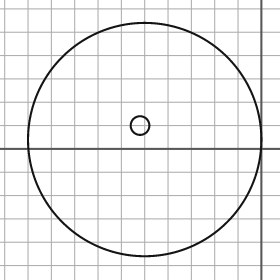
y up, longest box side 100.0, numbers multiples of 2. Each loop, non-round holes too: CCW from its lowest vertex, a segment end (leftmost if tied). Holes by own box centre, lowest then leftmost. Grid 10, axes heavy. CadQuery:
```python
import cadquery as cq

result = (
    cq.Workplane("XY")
    .moveTo(-50.0, 4.0)
    .circle(50.0)
    .moveTo(-52.0, 10.0)
    .circle(4.0)
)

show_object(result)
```